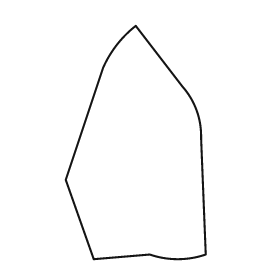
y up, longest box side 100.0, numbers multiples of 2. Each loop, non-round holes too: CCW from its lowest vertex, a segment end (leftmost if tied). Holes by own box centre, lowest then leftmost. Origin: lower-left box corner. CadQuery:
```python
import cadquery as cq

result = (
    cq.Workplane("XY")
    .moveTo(12.0, 0.0)
    .lineTo(36.0, 2.0)
    .threePointArc((48.0, 0.0), (60.0, 2.0))
    .lineTo(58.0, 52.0)
    .threePointArc((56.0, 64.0), (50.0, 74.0))
    .lineTo(30.0, 100.0)
    .threePointArc((22.0, 92.0), (16.0, 82.0))
    .lineTo(0.0, 34.0)
    .close()
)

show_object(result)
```